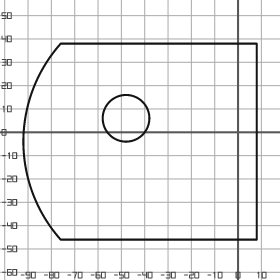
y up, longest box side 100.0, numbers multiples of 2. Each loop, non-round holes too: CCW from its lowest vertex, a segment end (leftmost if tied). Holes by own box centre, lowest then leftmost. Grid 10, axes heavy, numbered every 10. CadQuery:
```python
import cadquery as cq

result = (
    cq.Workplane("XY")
    .moveTo(-76.0, -46.0)
    .lineTo(8.0, -46.0)
    .lineTo(8.0, 38.0)
    .lineTo(-76.0, 38.0)
    .threePointArc((-92.0, -4.0), (-76.0, -46.0))
    .close()
    .moveTo(-48.0, 6.0)
    .circle(10.0)
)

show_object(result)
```